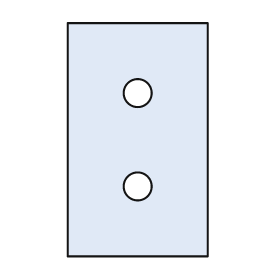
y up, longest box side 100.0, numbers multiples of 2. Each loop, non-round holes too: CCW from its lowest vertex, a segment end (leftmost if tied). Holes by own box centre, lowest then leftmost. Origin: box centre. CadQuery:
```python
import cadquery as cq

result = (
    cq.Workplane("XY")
    .moveTo(-30.0, -50.0)
    .lineTo(30.0, -50.0)
    .lineTo(30.0, 50.0)
    .lineTo(-30.0, 50.0)
    .close()
    .moveTo(0.0, -20.0)
    .circle(6.0)
    .moveTo(0.0, 20.0)
    .circle(6.0)
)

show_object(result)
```